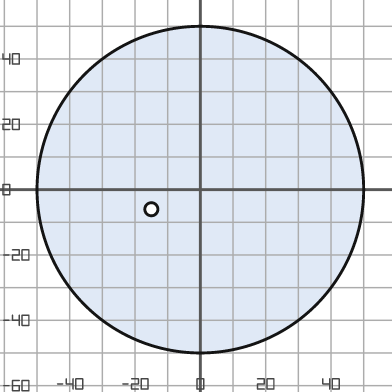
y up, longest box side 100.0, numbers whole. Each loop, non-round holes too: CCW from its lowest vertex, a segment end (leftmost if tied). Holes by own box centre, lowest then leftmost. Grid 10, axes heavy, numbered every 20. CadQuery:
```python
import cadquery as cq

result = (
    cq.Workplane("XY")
    .moveTo(0.0, 0.0)
    .circle(50.0)
    .moveTo(-15.0, -6.0)
    .circle(2.0)
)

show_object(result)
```